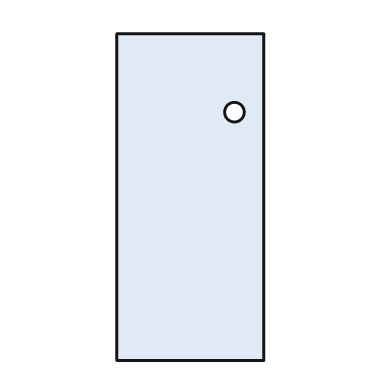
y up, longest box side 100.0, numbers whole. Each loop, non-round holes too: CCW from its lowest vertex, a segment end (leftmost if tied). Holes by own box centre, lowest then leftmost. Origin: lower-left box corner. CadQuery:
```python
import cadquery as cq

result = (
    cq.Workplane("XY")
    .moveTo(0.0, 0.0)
    .lineTo(45.0, 0.0)
    .lineTo(45.0, 100.0)
    .lineTo(0.0, 100.0)
    .close()
    .moveTo(36.0, 76.0)
    .circle(3.0)
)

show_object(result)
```